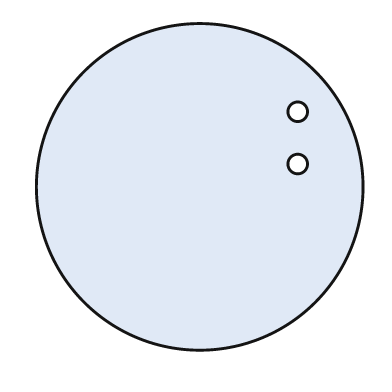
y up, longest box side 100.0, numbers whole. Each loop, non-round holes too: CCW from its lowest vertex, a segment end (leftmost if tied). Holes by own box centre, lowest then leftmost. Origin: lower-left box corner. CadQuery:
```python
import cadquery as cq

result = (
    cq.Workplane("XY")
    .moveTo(50.0, 50.0)
    .circle(50.0)
    .moveTo(80.0, 57.0)
    .circle(3.0)
    .moveTo(80.0, 73.0)
    .circle(3.0)
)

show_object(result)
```